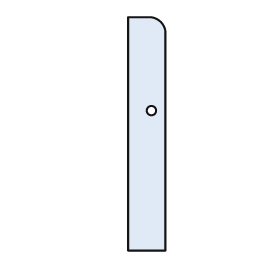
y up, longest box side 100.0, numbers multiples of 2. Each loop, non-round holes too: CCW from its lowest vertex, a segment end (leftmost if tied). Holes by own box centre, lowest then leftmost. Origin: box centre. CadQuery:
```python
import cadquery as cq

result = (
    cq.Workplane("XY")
    .moveTo(-8.0, -50.0)
    .lineTo(8.0, -50.0)
    .lineTo(8.0, 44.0)
    .threePointArc((6.0, 48.0), (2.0, 50.0))
    .lineTo(-8.0, 50.0)
    .close()
    .moveTo(2.0, 10.0)
    .circle(2.0)
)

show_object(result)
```